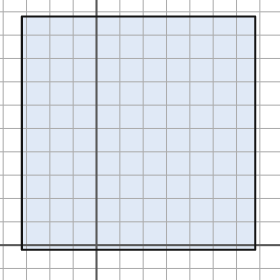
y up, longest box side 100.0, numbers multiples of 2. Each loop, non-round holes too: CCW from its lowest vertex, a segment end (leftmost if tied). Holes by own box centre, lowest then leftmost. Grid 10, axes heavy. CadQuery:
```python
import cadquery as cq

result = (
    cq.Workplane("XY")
    .moveTo(-32.0, -2.0)
    .lineTo(68.0, -2.0)
    .lineTo(68.0, 98.0)
    .lineTo(-32.0, 98.0)
    .close()
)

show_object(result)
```